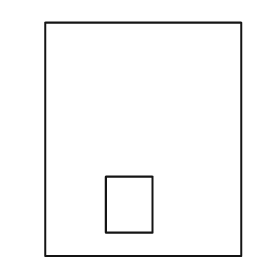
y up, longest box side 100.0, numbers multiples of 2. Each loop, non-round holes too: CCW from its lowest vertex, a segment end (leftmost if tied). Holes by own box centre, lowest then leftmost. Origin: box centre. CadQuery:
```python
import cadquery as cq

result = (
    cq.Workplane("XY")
    .moveTo(-42.0, -50.0)
    .lineTo(42.0, -50.0)
    .lineTo(42.0, 50.0)
    .lineTo(-42.0, 50.0)
    .close()
    .moveTo(-16.0, -40.0)
    .lineTo(4.0, -40.0)
    .lineTo(4.0, -16.0)
    .lineTo(-16.0, -16.0)
    .close()
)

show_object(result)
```